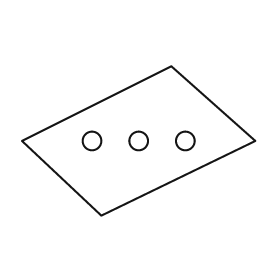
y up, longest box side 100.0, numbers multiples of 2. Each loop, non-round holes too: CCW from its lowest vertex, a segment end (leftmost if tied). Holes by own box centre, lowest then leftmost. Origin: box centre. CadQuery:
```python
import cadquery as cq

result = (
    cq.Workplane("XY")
    .moveTo(-16.0, -32.0)
    .lineTo(50.0, 0.0)
    .lineTo(14.0, 32.0)
    .lineTo(-50.0, 0.0)
    .close()
    .moveTo(-20.0, 0.0)
    .circle(4.0)
    .moveTo(0.0, 0.0)
    .circle(4.0)
    .moveTo(20.0, 0.0)
    .circle(4.0)
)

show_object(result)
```